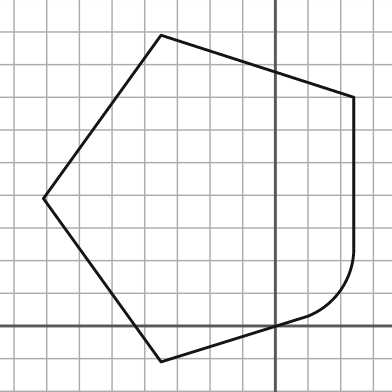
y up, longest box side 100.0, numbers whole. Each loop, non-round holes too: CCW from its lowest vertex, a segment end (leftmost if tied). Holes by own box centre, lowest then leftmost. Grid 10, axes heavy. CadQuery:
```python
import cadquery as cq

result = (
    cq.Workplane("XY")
    .moveTo(-35.0, -11.0)
    .lineTo(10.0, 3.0)
    .threePointArc((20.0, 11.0), (24.0, 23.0))
    .lineTo(24.0, 70.0)
    .lineTo(-35.0, 89.0)
    .lineTo(-71.0, 39.0)
    .close()
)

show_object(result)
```